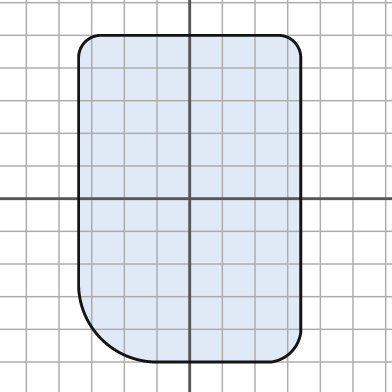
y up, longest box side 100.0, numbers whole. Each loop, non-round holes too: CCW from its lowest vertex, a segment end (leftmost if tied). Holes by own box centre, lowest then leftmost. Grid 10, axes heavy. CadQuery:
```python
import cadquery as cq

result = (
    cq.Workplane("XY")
    .moveTo(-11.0, -50.0)
    .lineTo(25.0, -50.0)
    .threePointArc((31.0, -47.0), (34.0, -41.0))
    .lineTo(34.0, 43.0)
    .threePointArc((32.0, 48.0), (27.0, 50.0))
    .lineTo(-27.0, 50.0)
    .threePointArc((-32.0, 48.0), (-34.0, 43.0))
    .lineTo(-34.0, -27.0)
    .threePointArc((-27.0, -43.0), (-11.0, -50.0))
    .close()
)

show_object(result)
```